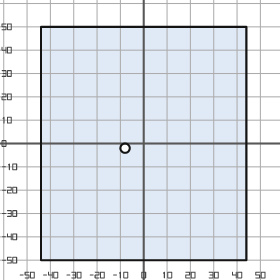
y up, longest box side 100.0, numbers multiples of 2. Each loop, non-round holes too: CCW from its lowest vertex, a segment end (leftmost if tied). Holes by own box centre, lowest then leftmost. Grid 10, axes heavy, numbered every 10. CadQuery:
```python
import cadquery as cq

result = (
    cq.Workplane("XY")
    .moveTo(-44.0, -50.0)
    .lineTo(44.0, -50.0)
    .lineTo(44.0, 50.0)
    .lineTo(-44.0, 50.0)
    .close()
    .moveTo(-8.0, -2.0)
    .circle(2.0)
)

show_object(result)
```